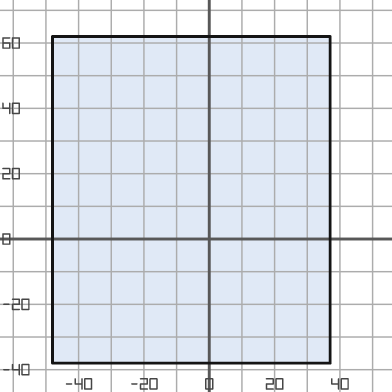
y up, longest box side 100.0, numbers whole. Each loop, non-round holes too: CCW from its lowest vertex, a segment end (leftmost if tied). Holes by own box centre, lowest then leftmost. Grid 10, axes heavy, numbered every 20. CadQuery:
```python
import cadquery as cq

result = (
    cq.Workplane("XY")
    .moveTo(-48.0, -38.0)
    .lineTo(37.0, -38.0)
    .lineTo(37.0, 62.0)
    .lineTo(-48.0, 62.0)
    .close()
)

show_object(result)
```